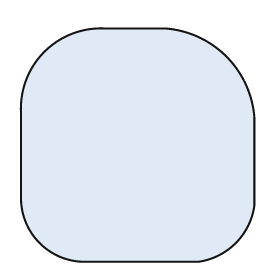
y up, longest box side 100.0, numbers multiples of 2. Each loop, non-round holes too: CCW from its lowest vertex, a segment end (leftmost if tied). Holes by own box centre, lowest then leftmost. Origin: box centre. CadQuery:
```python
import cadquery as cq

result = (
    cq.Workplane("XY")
    .moveTo(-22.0, -50.0)
    .lineTo(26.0, -50.0)
    .threePointArc((42.0, -42.0), (50.0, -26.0))
    .lineTo(50.0, 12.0)
    .threePointArc((38.0, 38.0), (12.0, 50.0))
    .lineTo(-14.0, 50.0)
    .threePointArc((-40.0, 40.0), (-50.0, 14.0))
    .lineTo(-50.0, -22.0)
    .threePointArc((-42.0, -42.0), (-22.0, -50.0))
    .close()
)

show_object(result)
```